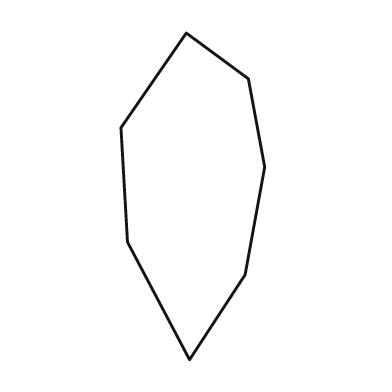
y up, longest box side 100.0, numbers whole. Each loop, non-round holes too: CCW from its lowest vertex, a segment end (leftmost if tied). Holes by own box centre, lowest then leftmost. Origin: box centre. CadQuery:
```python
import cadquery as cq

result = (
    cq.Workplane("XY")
    .moveTo(-1.0, -50.0)
    .lineTo(16.0, -24.0)
    .lineTo(22.0, 9.0)
    .lineTo(17.0, 36.0)
    .lineTo(-2.0, 50.0)
    .lineTo(-22.0, 21.0)
    .lineTo(-20.0, -14.0)
    .close()
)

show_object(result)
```